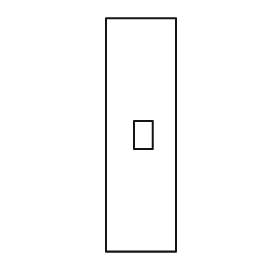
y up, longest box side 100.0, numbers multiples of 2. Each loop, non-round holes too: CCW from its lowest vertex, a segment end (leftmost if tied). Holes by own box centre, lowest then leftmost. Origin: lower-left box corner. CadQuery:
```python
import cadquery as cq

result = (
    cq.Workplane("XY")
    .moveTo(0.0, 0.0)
    .lineTo(30.0, 0.0)
    .lineTo(30.0, 100.0)
    .lineTo(0.0, 100.0)
    .close()
    .moveTo(12.0, 44.0)
    .lineTo(20.0, 44.0)
    .lineTo(20.0, 56.0)
    .lineTo(12.0, 56.0)
    .close()
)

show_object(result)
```